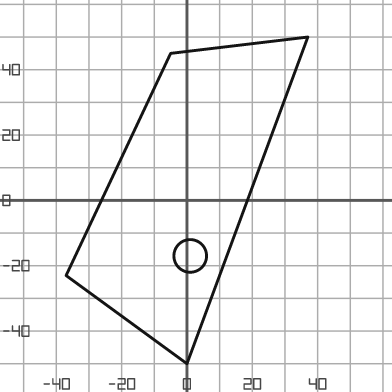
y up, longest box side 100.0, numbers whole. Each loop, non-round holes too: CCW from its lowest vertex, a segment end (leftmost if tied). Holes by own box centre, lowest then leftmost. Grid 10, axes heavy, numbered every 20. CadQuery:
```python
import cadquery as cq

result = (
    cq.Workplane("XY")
    .moveTo(0.0, -50.0)
    .lineTo(37.0, 50.0)
    .lineTo(-5.0, 45.0)
    .lineTo(-37.0, -23.0)
    .close()
    .moveTo(1.0, -17.0)
    .circle(5.0)
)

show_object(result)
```